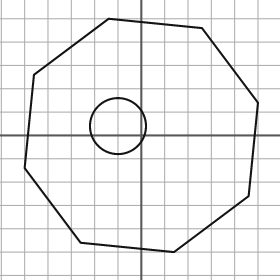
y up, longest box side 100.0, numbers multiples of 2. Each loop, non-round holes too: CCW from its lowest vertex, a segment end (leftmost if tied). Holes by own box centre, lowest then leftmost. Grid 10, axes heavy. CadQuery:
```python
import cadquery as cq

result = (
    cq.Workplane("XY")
    .moveTo(14.0, -50.0)
    .lineTo(46.0, -26.0)
    .lineTo(50.0, 14.0)
    .lineTo(26.0, 46.0)
    .lineTo(-14.0, 50.0)
    .lineTo(-46.0, 26.0)
    .lineTo(-50.0, -14.0)
    .lineTo(-26.0, -46.0)
    .close()
    .moveTo(-10.0, 4.0)
    .circle(12.0)
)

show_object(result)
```